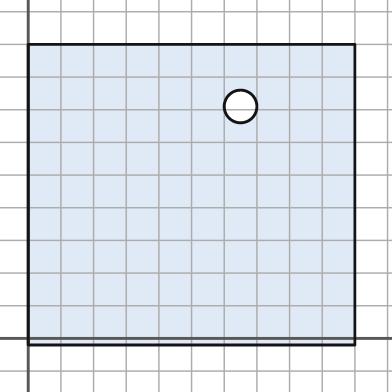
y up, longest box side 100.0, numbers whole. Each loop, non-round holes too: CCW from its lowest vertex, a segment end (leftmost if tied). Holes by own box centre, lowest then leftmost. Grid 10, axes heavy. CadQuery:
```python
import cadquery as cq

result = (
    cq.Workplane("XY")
    .moveTo(0.0, -2.0)
    .lineTo(100.0, -2.0)
    .lineTo(100.0, 90.0)
    .lineTo(0.0, 90.0)
    .close()
    .moveTo(65.0, 71.0)
    .circle(5.0)
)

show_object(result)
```